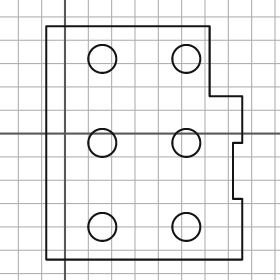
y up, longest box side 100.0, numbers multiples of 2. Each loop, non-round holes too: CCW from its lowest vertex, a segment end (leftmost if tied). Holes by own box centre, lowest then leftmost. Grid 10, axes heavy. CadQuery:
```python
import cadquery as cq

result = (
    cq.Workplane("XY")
    .moveTo(-8.0, -54.0)
    .lineTo(76.0, -54.0)
    .lineTo(76.0, -28.0)
    .lineTo(72.0, -28.0)
    .lineTo(72.0, -4.0)
    .lineTo(76.0, -4.0)
    .lineTo(76.0, 16.0)
    .lineTo(62.0, 16.0)
    .lineTo(62.0, 46.0)
    .lineTo(-8.0, 46.0)
    .close()
    .moveTo(16.0, -40.0)
    .circle(6.0)
    .moveTo(52.0, -40.0)
    .circle(6.0)
    .moveTo(16.0, -4.0)
    .circle(6.0)
    .moveTo(52.0, -4.0)
    .circle(6.0)
    .moveTo(16.0, 32.0)
    .circle(6.0)
    .moveTo(52.0, 32.0)
    .circle(6.0)
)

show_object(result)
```